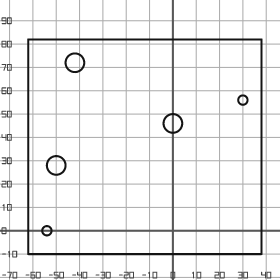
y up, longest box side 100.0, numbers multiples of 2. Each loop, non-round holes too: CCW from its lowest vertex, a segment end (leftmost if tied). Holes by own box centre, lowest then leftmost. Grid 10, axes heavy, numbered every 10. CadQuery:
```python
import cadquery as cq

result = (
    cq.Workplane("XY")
    .moveTo(-62.0, -10.0)
    .lineTo(38.0, -10.0)
    .lineTo(38.0, 82.0)
    .lineTo(-62.0, 82.0)
    .close()
    .moveTo(-54.0, 0.0)
    .circle(2.0)
    .moveTo(-50.0, 28.0)
    .circle(4.0)
    .moveTo(0.0, 46.0)
    .circle(4.0)
    .moveTo(30.0, 56.0)
    .circle(2.0)
    .moveTo(-42.0, 72.0)
    .circle(4.0)
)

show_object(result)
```